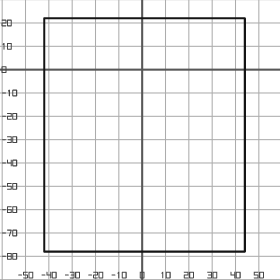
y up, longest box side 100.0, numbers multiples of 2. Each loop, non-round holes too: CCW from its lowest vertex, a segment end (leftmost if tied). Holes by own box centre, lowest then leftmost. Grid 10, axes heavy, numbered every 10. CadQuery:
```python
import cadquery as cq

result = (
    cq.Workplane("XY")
    .moveTo(-42.0, -78.0)
    .lineTo(44.0, -78.0)
    .lineTo(44.0, 22.0)
    .lineTo(-42.0, 22.0)
    .close()
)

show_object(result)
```